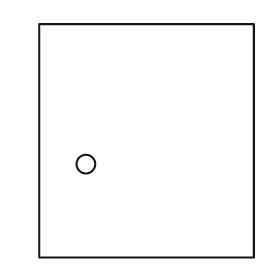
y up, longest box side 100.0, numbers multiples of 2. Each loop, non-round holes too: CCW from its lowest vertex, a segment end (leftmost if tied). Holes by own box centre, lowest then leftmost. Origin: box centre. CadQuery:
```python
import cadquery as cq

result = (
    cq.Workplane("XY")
    .moveTo(-46.0, -50.0)
    .lineTo(46.0, -50.0)
    .lineTo(46.0, 50.0)
    .lineTo(-46.0, 50.0)
    .close()
    .moveTo(-26.0, -10.0)
    .circle(4.0)
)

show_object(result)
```